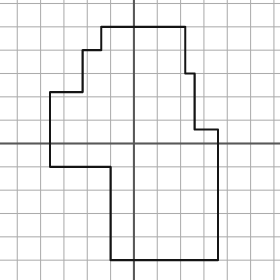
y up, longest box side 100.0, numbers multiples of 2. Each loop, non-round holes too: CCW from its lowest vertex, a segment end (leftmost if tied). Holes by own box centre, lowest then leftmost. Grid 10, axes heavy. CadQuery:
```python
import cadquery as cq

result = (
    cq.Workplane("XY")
    .moveTo(-10.0, -50.0)
    .lineTo(36.0, -50.0)
    .lineTo(36.0, 6.0)
    .lineTo(26.0, 6.0)
    .lineTo(26.0, 30.0)
    .lineTo(22.0, 30.0)
    .lineTo(22.0, 50.0)
    .lineTo(-14.0, 50.0)
    .lineTo(-14.0, 40.0)
    .lineTo(-22.0, 40.0)
    .lineTo(-22.0, 22.0)
    .lineTo(-36.0, 22.0)
    .lineTo(-36.0, -10.0)
    .lineTo(-10.0, -10.0)
    .close()
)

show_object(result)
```